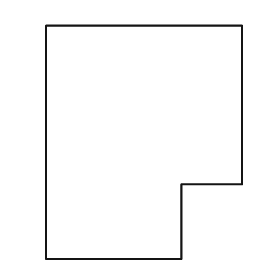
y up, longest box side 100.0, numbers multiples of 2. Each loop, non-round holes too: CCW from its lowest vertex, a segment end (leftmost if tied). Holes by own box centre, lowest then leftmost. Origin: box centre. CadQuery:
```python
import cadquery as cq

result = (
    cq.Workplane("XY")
    .moveTo(-42.0, -50.0)
    .lineTo(16.0, -50.0)
    .lineTo(16.0, -18.0)
    .lineTo(42.0, -18.0)
    .lineTo(42.0, 50.0)
    .lineTo(-42.0, 50.0)
    .close()
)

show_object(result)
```